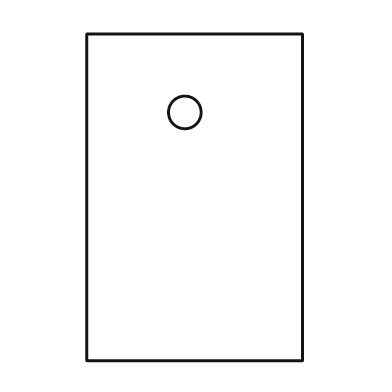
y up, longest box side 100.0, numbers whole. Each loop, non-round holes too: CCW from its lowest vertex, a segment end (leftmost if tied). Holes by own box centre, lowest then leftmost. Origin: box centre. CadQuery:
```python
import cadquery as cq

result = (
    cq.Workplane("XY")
    .moveTo(-33.0, -50.0)
    .lineTo(33.0, -50.0)
    .lineTo(33.0, 50.0)
    .lineTo(-33.0, 50.0)
    .close()
    .moveTo(-3.0, 26.0)
    .circle(5.0)
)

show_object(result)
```